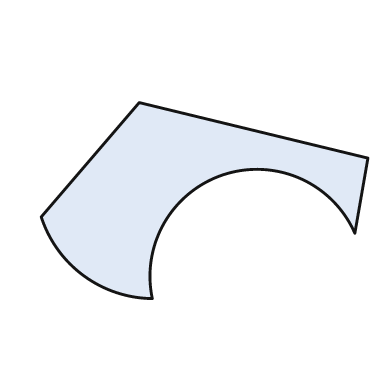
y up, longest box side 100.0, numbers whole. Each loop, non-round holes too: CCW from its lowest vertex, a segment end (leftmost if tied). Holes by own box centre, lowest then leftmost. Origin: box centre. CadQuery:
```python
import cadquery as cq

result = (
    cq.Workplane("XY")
    .moveTo(-16.0, -30.0)
    .threePointArc((6.0, 8.0), (46.0, -10.0))
    .lineTo(50.0, 13.0)
    .lineTo(-20.0, 30.0)
    .lineTo(-50.0, -5.0)
    .threePointArc((-37.0, -23.0), (-16.0, -30.0))
    .close()
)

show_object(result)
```